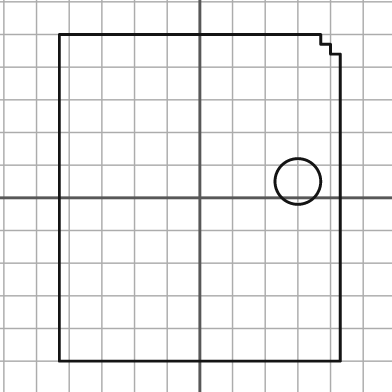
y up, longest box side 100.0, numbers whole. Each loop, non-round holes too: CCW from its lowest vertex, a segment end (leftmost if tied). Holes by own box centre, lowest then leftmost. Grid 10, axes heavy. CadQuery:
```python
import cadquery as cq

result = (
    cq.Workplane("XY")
    .moveTo(-43.0, -50.0)
    .lineTo(43.0, -50.0)
    .lineTo(43.0, 44.0)
    .lineTo(40.0, 44.0)
    .lineTo(40.0, 47.0)
    .lineTo(37.0, 47.0)
    .lineTo(37.0, 50.0)
    .lineTo(-43.0, 50.0)
    .close()
    .moveTo(30.0, 5.0)
    .circle(7.0)
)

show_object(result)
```